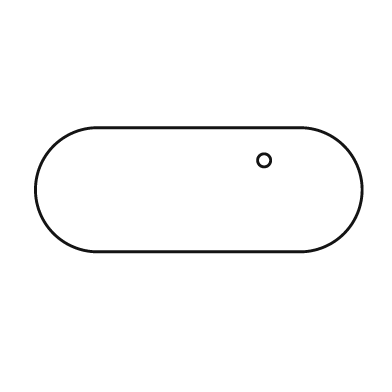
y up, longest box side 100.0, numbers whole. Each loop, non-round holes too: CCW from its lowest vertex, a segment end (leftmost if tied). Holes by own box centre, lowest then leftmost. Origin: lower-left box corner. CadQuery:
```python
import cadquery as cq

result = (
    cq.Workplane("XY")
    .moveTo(19.0, 0.0)
    .lineTo(81.0, 0.0)
    .threePointArc((100.0, 19.0), (81.0, 38.0))
    .lineTo(19.0, 38.0)
    .threePointArc((0.0, 19.0), (19.0, 0.0))
    .close()
    .moveTo(70.0, 28.0)
    .circle(2.0)
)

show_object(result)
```